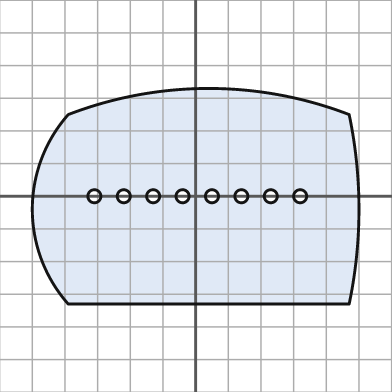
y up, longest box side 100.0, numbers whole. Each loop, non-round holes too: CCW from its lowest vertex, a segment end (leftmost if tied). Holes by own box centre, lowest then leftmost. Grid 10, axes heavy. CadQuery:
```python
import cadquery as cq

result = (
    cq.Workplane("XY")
    .moveTo(-39.0, -33.0)
    .lineTo(47.0, -33.0)
    .threePointArc((50.0, -4.0), (47.0, 25.0))
    .threePointArc((4.0, 33.0), (-39.0, 25.0))
    .threePointArc((-50.0, -4.0), (-39.0, -33.0))
    .close()
    .moveTo(-31.0, 0.0)
    .circle(2.0)
    .moveTo(-22.0, 0.0)
    .circle(2.0)
    .moveTo(-13.0, 0.0)
    .circle(2.0)
    .moveTo(-4.0, 0.0)
    .circle(2.0)
    .moveTo(5.0, 0.0)
    .circle(2.0)
    .moveTo(14.0, 0.0)
    .circle(2.0)
    .moveTo(23.0, 0.0)
    .circle(2.0)
    .moveTo(32.0, 0.0)
    .circle(2.0)
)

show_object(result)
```